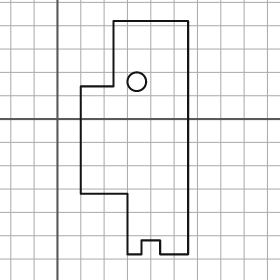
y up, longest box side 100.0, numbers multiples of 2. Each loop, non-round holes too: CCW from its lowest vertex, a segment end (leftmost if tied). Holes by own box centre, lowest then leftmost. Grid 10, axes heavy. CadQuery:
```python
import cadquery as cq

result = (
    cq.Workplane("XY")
    .moveTo(30.0, -58.0)
    .lineTo(36.0, -58.0)
    .lineTo(36.0, -52.0)
    .lineTo(44.0, -52.0)
    .lineTo(44.0, -58.0)
    .lineTo(56.0, -58.0)
    .lineTo(56.0, 42.0)
    .lineTo(24.0, 42.0)
    .lineTo(24.0, 14.0)
    .lineTo(10.0, 14.0)
    .lineTo(10.0, -32.0)
    .lineTo(30.0, -32.0)
    .close()
    .moveTo(34.0, 16.0)
    .circle(4.0)
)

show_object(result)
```